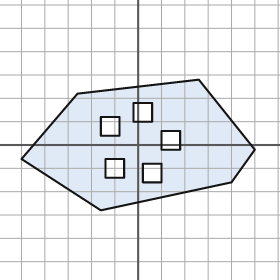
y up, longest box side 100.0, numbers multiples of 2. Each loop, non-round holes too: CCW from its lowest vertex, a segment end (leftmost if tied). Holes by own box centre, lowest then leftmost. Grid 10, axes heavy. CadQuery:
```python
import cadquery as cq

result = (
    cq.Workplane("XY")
    .moveTo(-16.0, -28.0)
    .lineTo(40.0, -16.0)
    .lineTo(50.0, -2.0)
    .lineTo(26.0, 28.0)
    .lineTo(-26.0, 22.0)
    .lineTo(-50.0, -6.0)
    .close()
    .moveTo(2.0, -16.0)
    .lineTo(10.0, -16.0)
    .lineTo(10.0, -8.0)
    .lineTo(2.0, -8.0)
    .close()
    .moveTo(-14.0, -14.0)
    .lineTo(-6.0, -14.0)
    .lineTo(-6.0, -6.0)
    .lineTo(-14.0, -6.0)
    .close()
    .moveTo(10.0, -2.0)
    .lineTo(18.0, -2.0)
    .lineTo(18.0, 6.0)
    .lineTo(10.0, 6.0)
    .close()
    .moveTo(-16.0, 4.0)
    .lineTo(-8.0, 4.0)
    .lineTo(-8.0, 12.0)
    .lineTo(-16.0, 12.0)
    .close()
    .moveTo(-2.0, 10.0)
    .lineTo(6.0, 10.0)
    .lineTo(6.0, 18.0)
    .lineTo(-2.0, 18.0)
    .close()
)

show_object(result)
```